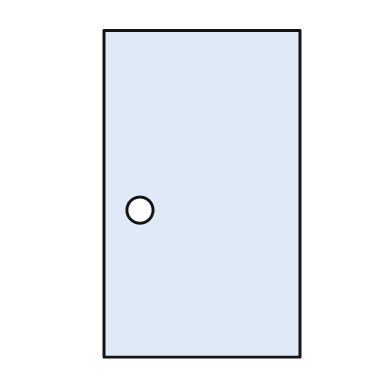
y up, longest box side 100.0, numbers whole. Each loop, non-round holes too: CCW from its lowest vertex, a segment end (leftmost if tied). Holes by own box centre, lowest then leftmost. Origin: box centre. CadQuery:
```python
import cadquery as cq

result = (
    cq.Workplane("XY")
    .moveTo(-30.0, -50.0)
    .lineTo(30.0, -50.0)
    .lineTo(30.0, 50.0)
    .lineTo(-30.0, 50.0)
    .close()
    .moveTo(-19.0, -5.0)
    .circle(4.0)
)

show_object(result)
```